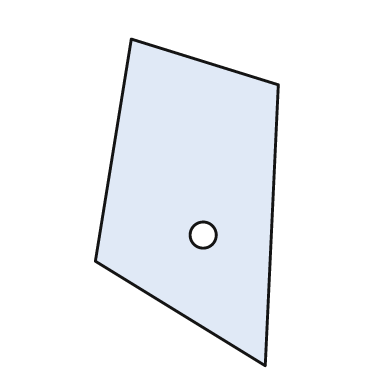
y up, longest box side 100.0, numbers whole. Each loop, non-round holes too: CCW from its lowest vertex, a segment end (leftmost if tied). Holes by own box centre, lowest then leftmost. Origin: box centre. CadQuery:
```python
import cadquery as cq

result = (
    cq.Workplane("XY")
    .moveTo(24.0, -50.0)
    .lineTo(28.0, 36.0)
    .lineTo(-17.0, 50.0)
    .lineTo(-28.0, -18.0)
    .close()
    .moveTo(5.0, -10.0)
    .circle(4.0)
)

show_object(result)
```